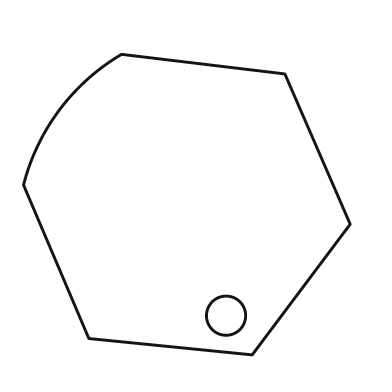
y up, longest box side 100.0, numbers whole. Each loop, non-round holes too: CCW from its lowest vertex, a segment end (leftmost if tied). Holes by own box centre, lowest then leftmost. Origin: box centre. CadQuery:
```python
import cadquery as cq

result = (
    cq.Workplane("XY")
    .moveTo(20.0, -46.0)
    .lineTo(50.0, -6.0)
    .lineTo(30.0, 40.0)
    .lineTo(-20.0, 46.0)
    .threePointArc((-39.0, 29.0), (-50.0, 6.0))
    .lineTo(-30.0, -41.0)
    .close()
    .moveTo(12.0, -34.0)
    .circle(6.0)
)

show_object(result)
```